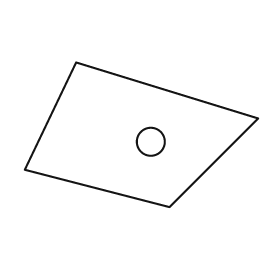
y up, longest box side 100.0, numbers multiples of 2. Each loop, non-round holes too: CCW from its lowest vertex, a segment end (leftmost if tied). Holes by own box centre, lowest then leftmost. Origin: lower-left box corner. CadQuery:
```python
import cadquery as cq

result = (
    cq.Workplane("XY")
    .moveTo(62.0, 0.0)
    .lineTo(100.0, 38.0)
    .lineTo(22.0, 62.0)
    .lineTo(0.0, 16.0)
    .close()
    .moveTo(54.0, 28.0)
    .circle(6.0)
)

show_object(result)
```